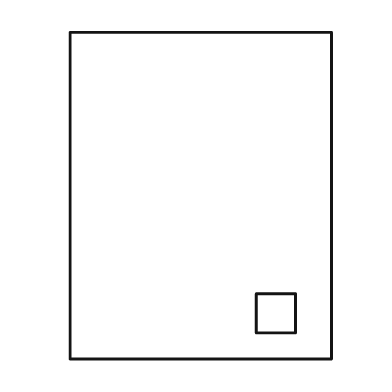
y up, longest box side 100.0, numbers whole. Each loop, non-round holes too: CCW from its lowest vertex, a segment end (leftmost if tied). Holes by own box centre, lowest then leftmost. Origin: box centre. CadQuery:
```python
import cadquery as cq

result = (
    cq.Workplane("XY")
    .moveTo(-40.0, -50.0)
    .lineTo(40.0, -50.0)
    .lineTo(40.0, 50.0)
    .lineTo(-40.0, 50.0)
    .close()
    .moveTo(17.0, -42.0)
    .lineTo(29.0, -42.0)
    .lineTo(29.0, -30.0)
    .lineTo(17.0, -30.0)
    .close()
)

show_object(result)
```